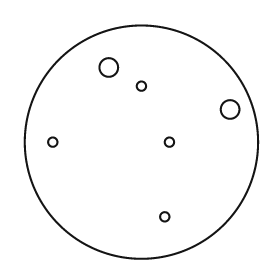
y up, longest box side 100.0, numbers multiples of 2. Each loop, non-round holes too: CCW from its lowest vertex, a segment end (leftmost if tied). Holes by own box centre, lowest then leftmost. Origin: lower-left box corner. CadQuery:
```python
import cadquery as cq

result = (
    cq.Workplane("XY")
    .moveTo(50.0, 50.0)
    .circle(50.0)
    .moveTo(60.0, 18.0)
    .circle(2.0)
    .moveTo(12.0, 50.0)
    .circle(2.0)
    .moveTo(62.0, 50.0)
    .circle(2.0)
    .moveTo(88.0, 64.0)
    .circle(4.0)
    .moveTo(50.0, 74.0)
    .circle(2.0)
    .moveTo(36.0, 82.0)
    .circle(4.0)
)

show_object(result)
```